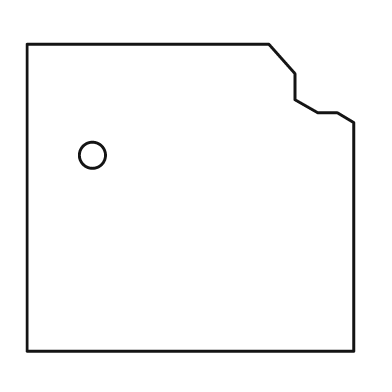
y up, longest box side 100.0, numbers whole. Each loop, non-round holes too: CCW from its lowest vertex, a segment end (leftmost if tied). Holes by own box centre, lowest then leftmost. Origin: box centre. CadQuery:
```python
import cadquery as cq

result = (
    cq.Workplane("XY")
    .moveTo(-50.0, -47.0)
    .lineTo(50.0, -47.0)
    .lineTo(50.0, 23.0)
    .lineTo(45.0, 26.0)
    .lineTo(39.0, 26.0)
    .lineTo(32.0, 30.0)
    .lineTo(32.0, 38.0)
    .lineTo(24.0, 47.0)
    .lineTo(-50.0, 47.0)
    .close()
    .moveTo(-30.0, 13.0)
    .circle(4.0)
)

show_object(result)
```